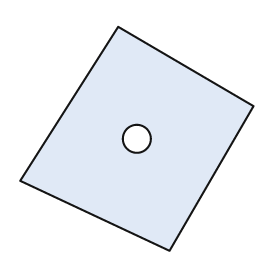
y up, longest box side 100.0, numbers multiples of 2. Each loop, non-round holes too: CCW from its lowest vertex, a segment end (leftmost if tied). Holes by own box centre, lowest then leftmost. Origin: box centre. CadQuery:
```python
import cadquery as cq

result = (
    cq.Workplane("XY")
    .moveTo(14.0, -48.0)
    .lineTo(50.0, 14.0)
    .lineTo(-8.0, 48.0)
    .lineTo(-50.0, -18.0)
    .close()
    .moveTo(0.0, 0.0)
    .circle(6.0)
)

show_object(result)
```